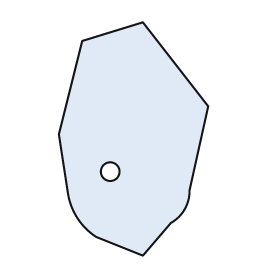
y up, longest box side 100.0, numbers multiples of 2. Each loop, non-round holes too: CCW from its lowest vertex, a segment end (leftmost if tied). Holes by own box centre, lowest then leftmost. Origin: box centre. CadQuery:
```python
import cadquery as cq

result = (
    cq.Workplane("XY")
    .moveTo(4.0, -50.0)
    .lineTo(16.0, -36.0)
    .threePointArc((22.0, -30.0), (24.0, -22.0))
    .lineTo(32.0, 14.0)
    .lineTo(4.0, 50.0)
    .lineTo(-22.0, 42.0)
    .lineTo(-32.0, 2.0)
    .lineTo(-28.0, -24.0)
    .threePointArc((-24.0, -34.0), (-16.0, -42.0))
    .close()
    .moveTo(-10.0, -14.0)
    .circle(4.0)
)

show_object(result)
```